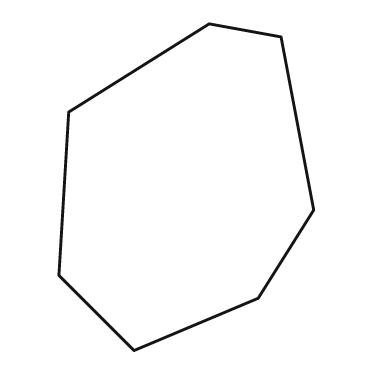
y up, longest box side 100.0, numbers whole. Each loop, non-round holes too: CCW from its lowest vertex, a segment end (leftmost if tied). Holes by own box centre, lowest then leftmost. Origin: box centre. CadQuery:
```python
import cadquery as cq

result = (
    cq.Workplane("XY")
    .moveTo(-16.0, -50.0)
    .lineTo(22.0, -34.0)
    .lineTo(39.0, -7.0)
    .lineTo(29.0, 46.0)
    .lineTo(7.0, 50.0)
    .lineTo(-36.0, 23.0)
    .lineTo(-39.0, -27.0)
    .close()
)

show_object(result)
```